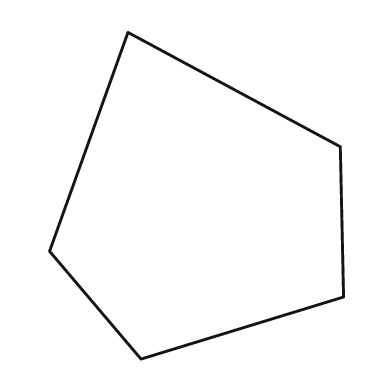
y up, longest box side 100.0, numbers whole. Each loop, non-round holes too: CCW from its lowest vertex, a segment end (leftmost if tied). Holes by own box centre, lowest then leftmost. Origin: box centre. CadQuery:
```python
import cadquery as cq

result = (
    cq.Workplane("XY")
    .moveTo(-17.0, -50.0)
    .lineTo(45.0, -31.0)
    .lineTo(44.0, 15.0)
    .lineTo(-21.0, 50.0)
    .lineTo(-45.0, -17.0)
    .close()
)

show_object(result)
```